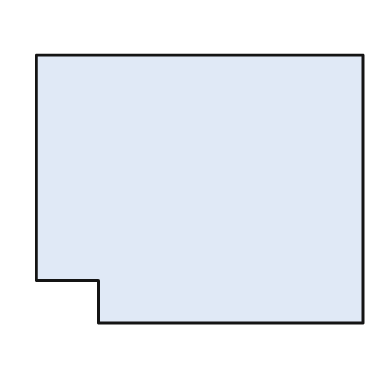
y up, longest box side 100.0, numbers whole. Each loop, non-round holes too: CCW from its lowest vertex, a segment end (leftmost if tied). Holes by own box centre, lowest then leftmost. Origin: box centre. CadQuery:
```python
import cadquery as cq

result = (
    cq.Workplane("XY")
    .moveTo(-31.0, -41.0)
    .lineTo(50.0, -41.0)
    .lineTo(50.0, 41.0)
    .lineTo(-50.0, 41.0)
    .lineTo(-50.0, -28.0)
    .lineTo(-31.0, -28.0)
    .close()
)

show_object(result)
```